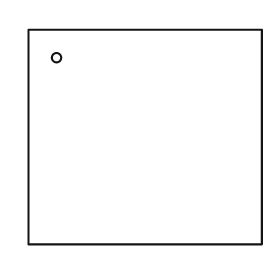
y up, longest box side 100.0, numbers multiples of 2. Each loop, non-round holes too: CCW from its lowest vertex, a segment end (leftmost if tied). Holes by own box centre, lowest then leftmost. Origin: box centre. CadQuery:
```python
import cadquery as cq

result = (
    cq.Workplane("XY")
    .moveTo(-50.0, -46.0)
    .lineTo(50.0, -46.0)
    .lineTo(50.0, 46.0)
    .lineTo(-50.0, 46.0)
    .close()
    .moveTo(-38.0, 34.0)
    .circle(2.0)
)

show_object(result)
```